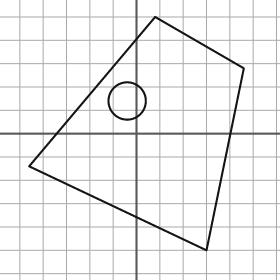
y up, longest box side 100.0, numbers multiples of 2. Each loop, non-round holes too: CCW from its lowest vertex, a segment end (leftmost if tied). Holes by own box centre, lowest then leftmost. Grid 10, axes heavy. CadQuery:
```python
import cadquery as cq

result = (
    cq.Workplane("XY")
    .moveTo(30.0, -50.0)
    .lineTo(46.0, 28.0)
    .lineTo(8.0, 50.0)
    .lineTo(-46.0, -14.0)
    .close()
    .moveTo(-4.0, 14.0)
    .circle(8.0)
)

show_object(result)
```